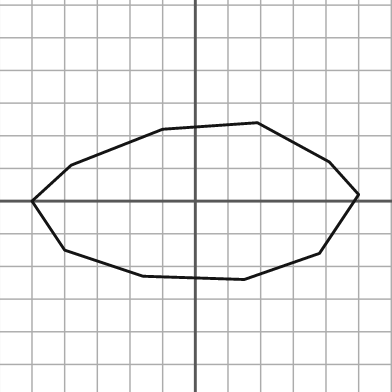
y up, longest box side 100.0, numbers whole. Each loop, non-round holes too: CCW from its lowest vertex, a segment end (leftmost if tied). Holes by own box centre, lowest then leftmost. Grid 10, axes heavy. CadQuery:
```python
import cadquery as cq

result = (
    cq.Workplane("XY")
    .moveTo(15.0, -24.0)
    .lineTo(38.0, -16.0)
    .lineTo(50.0, 2.0)
    .lineTo(41.0, 12.0)
    .lineTo(19.0, 24.0)
    .lineTo(-10.0, 22.0)
    .lineTo(-38.0, 11.0)
    .lineTo(-50.0, 0.0)
    .lineTo(-40.0, -15.0)
    .lineTo(-16.0, -23.0)
    .close()
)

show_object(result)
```